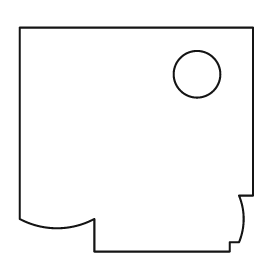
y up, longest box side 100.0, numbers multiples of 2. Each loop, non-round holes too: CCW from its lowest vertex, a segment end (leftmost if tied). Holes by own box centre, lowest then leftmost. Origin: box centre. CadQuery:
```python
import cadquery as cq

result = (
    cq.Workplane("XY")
    .moveTo(-18.0, -48.0)
    .lineTo(40.0, -48.0)
    .lineTo(40.0, -44.0)
    .lineTo(44.0, -44.0)
    .threePointArc((46.0, -34.0), (44.0, -24.0))
    .lineTo(50.0, -24.0)
    .lineTo(50.0, 48.0)
    .lineTo(-50.0, 48.0)
    .lineTo(-50.0, -34.0)
    .threePointArc((-34.0, -38.0), (-18.0, -34.0))
    .close()
    .moveTo(26.0, 28.0)
    .circle(10.0)
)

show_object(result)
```